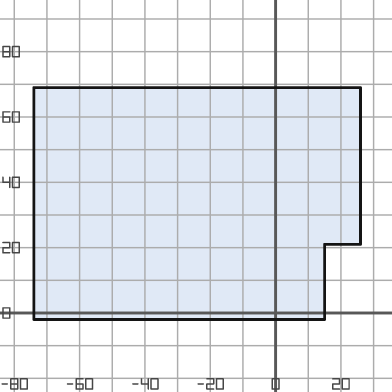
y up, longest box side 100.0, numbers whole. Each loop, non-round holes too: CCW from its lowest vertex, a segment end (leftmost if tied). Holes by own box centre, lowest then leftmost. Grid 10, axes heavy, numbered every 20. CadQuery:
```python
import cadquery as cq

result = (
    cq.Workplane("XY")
    .moveTo(-74.0, -2.0)
    .lineTo(15.0, -2.0)
    .lineTo(15.0, 21.0)
    .lineTo(26.0, 21.0)
    .lineTo(26.0, 69.0)
    .lineTo(-74.0, 69.0)
    .close()
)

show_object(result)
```